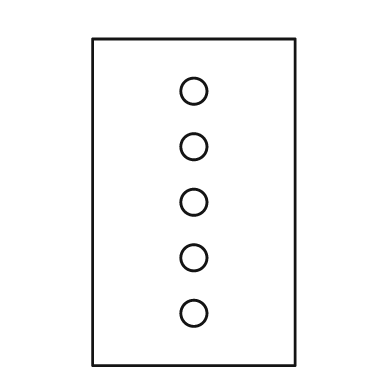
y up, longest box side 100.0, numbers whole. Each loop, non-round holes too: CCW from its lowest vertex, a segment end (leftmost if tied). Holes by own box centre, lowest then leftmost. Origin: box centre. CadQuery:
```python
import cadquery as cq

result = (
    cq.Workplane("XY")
    .moveTo(-31.0, -50.0)
    .lineTo(31.0, -50.0)
    .lineTo(31.0, 50.0)
    .lineTo(-31.0, 50.0)
    .close()
    .moveTo(0.0, -34.0)
    .circle(4.0)
    .moveTo(0.0, -17.0)
    .circle(4.0)
    .moveTo(0.0, 0.0)
    .circle(4.0)
    .moveTo(0.0, 17.0)
    .circle(4.0)
    .moveTo(0.0, 34.0)
    .circle(4.0)
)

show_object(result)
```